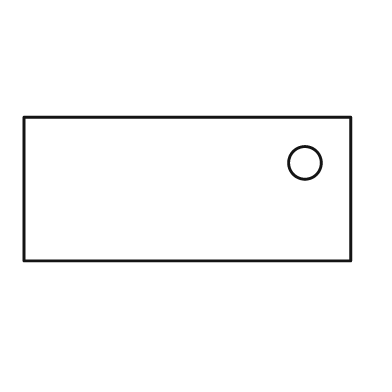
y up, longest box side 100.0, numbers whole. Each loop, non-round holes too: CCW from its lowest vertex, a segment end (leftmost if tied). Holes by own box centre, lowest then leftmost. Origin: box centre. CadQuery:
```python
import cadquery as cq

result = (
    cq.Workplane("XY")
    .moveTo(-50.0, -22.0)
    .lineTo(50.0, -22.0)
    .lineTo(50.0, 22.0)
    .lineTo(-50.0, 22.0)
    .close()
    .moveTo(36.0, 8.0)
    .circle(5.0)
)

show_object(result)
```